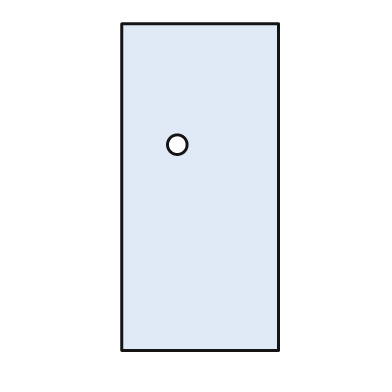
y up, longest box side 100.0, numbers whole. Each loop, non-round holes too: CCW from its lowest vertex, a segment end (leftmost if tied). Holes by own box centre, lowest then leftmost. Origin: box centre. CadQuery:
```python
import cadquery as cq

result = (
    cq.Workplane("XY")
    .moveTo(-24.0, -50.0)
    .lineTo(24.0, -50.0)
    .lineTo(24.0, 50.0)
    .lineTo(-24.0, 50.0)
    .close()
    .moveTo(-7.0, 13.0)
    .circle(3.0)
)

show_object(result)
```